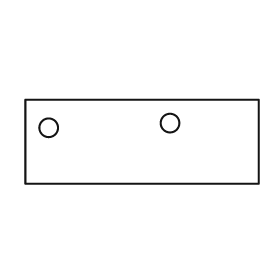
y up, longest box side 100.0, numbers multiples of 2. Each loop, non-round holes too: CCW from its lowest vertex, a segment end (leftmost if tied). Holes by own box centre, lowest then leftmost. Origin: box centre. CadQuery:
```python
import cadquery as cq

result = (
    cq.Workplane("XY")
    .moveTo(-50.0, -18.0)
    .lineTo(50.0, -18.0)
    .lineTo(50.0, 18.0)
    .lineTo(-50.0, 18.0)
    .close()
    .moveTo(-40.0, 6.0)
    .circle(4.0)
    .moveTo(12.0, 8.0)
    .circle(4.0)
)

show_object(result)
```